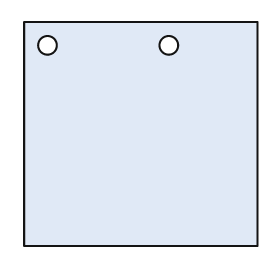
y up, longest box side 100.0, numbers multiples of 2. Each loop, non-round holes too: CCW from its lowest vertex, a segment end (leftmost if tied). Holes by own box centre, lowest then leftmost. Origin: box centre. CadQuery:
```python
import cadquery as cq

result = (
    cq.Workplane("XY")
    .moveTo(-50.0, -48.0)
    .lineTo(50.0, -48.0)
    .lineTo(50.0, 48.0)
    .lineTo(-50.0, 48.0)
    .close()
    .moveTo(-40.0, 38.0)
    .circle(4.0)
    .moveTo(12.0, 38.0)
    .circle(4.0)
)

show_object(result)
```